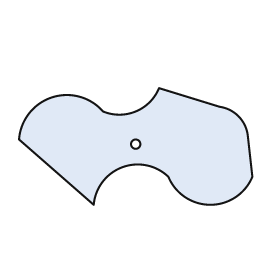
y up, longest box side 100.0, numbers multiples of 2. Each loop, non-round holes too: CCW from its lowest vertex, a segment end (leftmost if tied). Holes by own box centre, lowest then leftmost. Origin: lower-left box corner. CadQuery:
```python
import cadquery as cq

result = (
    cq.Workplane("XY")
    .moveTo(32.0, 0.0)
    .threePointArc((44.0, 16.0), (64.0, 12.0))
    .threePointArc((82.0, 0.0), (100.0, 12.0))
    .lineTo(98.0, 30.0)
    .threePointArc((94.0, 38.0), (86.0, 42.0))
    .lineTo(60.0, 50.0)
    .threePointArc((50.0, 40.0), (36.0, 40.0))
    .threePointArc((14.0, 46.0), (0.0, 28.0))
    .close()
    .moveTo(50.0, 26.0)
    .circle(2.0)
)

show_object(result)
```